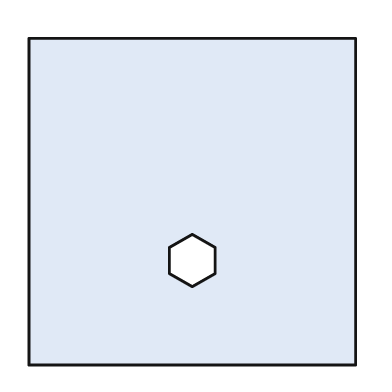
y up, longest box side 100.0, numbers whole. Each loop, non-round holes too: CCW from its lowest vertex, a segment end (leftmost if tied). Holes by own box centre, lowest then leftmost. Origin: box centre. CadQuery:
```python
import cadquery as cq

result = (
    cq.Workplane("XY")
    .moveTo(-50.0, -50.0)
    .lineTo(50.0, -50.0)
    .lineTo(50.0, 50.0)
    .lineTo(-50.0, 50.0)
    .close()
    .moveTo(0.0, -26.0)
    .lineTo(7.0, -22.0)
    .lineTo(7.0, -14.0)
    .lineTo(0.0, -10.0)
    .lineTo(-7.0, -14.0)
    .lineTo(-7.0, -22.0)
    .close()
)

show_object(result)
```